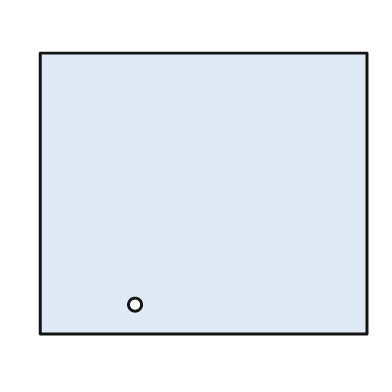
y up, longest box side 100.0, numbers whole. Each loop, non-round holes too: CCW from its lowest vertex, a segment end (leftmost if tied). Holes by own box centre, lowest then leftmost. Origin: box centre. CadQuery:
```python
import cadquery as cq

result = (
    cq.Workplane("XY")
    .moveTo(-50.0, -43.0)
    .lineTo(50.0, -43.0)
    .lineTo(50.0, 43.0)
    .lineTo(-50.0, 43.0)
    .close()
    .moveTo(-21.0, -34.0)
    .circle(2.0)
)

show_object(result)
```